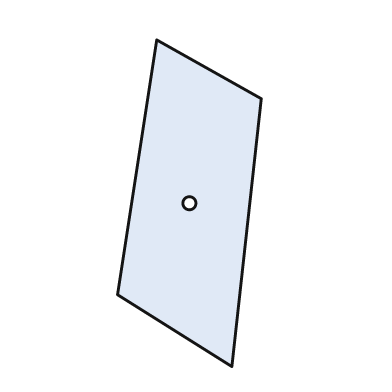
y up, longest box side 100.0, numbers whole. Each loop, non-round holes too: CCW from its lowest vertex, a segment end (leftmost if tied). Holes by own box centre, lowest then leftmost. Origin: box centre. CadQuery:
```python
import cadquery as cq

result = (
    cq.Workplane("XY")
    .moveTo(13.0, -50.0)
    .lineTo(22.0, 32.0)
    .lineTo(-10.0, 50.0)
    .lineTo(-22.0, -28.0)
    .close()
    .moveTo(0.0, 0.0)
    .circle(2.0)
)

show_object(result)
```